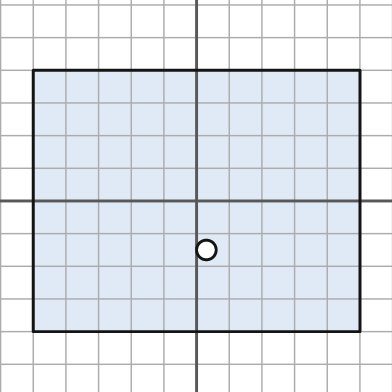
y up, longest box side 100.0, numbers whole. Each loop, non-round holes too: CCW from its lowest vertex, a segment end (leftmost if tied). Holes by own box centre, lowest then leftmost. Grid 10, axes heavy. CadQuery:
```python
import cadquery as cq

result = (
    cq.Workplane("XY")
    .moveTo(-50.0, -40.0)
    .lineTo(50.0, -40.0)
    .lineTo(50.0, 40.0)
    .lineTo(-50.0, 40.0)
    .close()
    .moveTo(3.0, -15.0)
    .circle(3.0)
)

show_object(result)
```